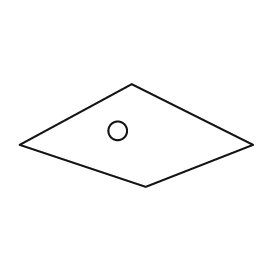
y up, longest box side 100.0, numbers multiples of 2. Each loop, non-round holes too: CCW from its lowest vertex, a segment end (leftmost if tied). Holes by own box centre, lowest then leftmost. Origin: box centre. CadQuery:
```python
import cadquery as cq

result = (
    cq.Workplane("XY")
    .moveTo(4.0, -22.0)
    .lineTo(50.0, -4.0)
    .lineTo(-2.0, 22.0)
    .lineTo(-50.0, -4.0)
    .close()
    .moveTo(-8.0, 2.0)
    .circle(4.0)
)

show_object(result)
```